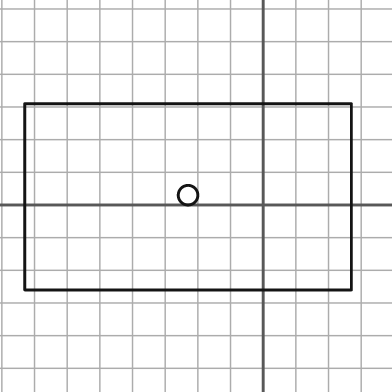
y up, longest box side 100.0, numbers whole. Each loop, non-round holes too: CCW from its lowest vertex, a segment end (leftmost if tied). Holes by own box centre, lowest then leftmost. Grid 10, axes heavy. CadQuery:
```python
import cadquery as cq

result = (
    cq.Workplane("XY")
    .moveTo(-73.0, -26.0)
    .lineTo(27.0, -26.0)
    .lineTo(27.0, 31.0)
    .lineTo(-73.0, 31.0)
    .close()
    .moveTo(-23.0, 3.0)
    .circle(3.0)
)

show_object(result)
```